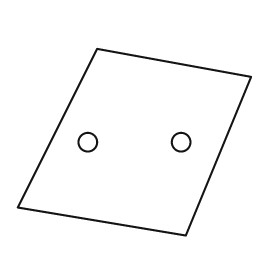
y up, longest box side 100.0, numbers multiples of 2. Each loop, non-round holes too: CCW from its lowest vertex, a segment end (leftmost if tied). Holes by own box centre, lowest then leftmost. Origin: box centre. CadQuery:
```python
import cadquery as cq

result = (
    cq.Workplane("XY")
    .moveTo(22.0, -40.0)
    .lineTo(50.0, 28.0)
    .lineTo(-16.0, 40.0)
    .lineTo(-50.0, -28.0)
    .close()
    .moveTo(-20.0, 0.0)
    .circle(4.0)
    .moveTo(20.0, 0.0)
    .circle(4.0)
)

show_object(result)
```